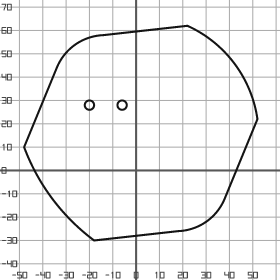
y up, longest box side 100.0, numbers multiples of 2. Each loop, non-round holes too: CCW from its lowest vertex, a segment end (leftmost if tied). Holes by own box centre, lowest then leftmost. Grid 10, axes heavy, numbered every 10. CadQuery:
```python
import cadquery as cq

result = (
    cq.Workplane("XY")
    .moveTo(-18.0, -30.0)
    .lineTo(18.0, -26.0)
    .threePointArc((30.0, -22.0), (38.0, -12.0))
    .lineTo(52.0, 22.0)
    .threePointArc((42.0, 46.0), (22.0, 62.0))
    .lineTo(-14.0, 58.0)
    .threePointArc((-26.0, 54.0), (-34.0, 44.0))
    .lineTo(-48.0, 10.0)
    .threePointArc((-36.0, -12.0), (-18.0, -30.0))
    .close()
    .moveTo(-20.0, 28.0)
    .circle(2.0)
    .moveTo(-6.0, 28.0)
    .circle(2.0)
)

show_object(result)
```